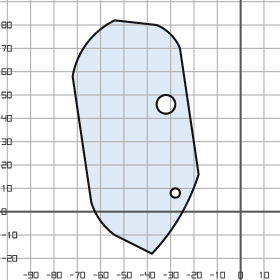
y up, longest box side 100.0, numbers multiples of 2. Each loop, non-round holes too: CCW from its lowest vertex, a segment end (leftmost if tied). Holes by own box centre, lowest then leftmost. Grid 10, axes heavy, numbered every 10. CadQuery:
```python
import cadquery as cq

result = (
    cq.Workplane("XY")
    .moveTo(-38.0, -18.0)
    .threePointArc((-26.0, -2.0), (-18.0, 16.0))
    .lineTo(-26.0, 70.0)
    .threePointArc((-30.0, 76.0), (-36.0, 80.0))
    .lineTo(-54.0, 82.0)
    .threePointArc((-66.0, 72.0), (-72.0, 58.0))
    .lineTo(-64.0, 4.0)
    .threePointArc((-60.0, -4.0), (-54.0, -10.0))
    .close()
    .moveTo(-28.0, 8.0)
    .circle(2.0)
    .moveTo(-32.0, 46.0)
    .circle(4.0)
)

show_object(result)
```